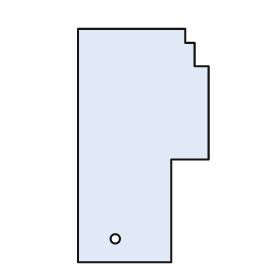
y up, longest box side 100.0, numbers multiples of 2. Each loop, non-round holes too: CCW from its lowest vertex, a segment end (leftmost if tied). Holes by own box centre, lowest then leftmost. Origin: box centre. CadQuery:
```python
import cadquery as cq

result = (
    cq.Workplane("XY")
    .moveTo(-28.0, -50.0)
    .lineTo(12.0, -50.0)
    .lineTo(12.0, -6.0)
    .lineTo(28.0, -6.0)
    .lineTo(28.0, 34.0)
    .lineTo(22.0, 34.0)
    .lineTo(22.0, 44.0)
    .lineTo(18.0, 44.0)
    .lineTo(18.0, 50.0)
    .lineTo(-28.0, 50.0)
    .close()
    .moveTo(-12.0, -40.0)
    .circle(2.0)
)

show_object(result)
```